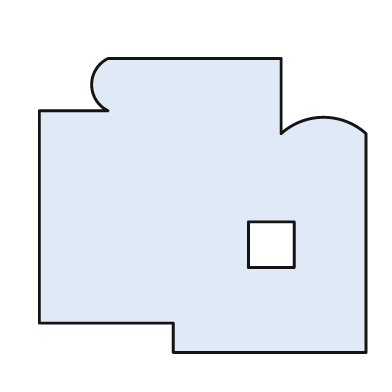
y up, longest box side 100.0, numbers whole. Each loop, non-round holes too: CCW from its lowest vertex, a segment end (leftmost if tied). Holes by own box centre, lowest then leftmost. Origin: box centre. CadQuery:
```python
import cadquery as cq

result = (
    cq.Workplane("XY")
    .moveTo(-9.0, -45.0)
    .lineTo(50.0, -45.0)
    .lineTo(50.0, 22.0)
    .threePointArc((37.0, 27.0), (24.0, 22.0))
    .lineTo(24.0, 45.0)
    .lineTo(-29.0, 45.0)
    .threePointArc((-34.0, 37.0), (-29.0, 29.0))
    .lineTo(-50.0, 29.0)
    .lineTo(-50.0, -36.0)
    .lineTo(-9.0, -36.0)
    .close()
    .moveTo(14.0, -19.0)
    .lineTo(28.0, -19.0)
    .lineTo(28.0, -5.0)
    .lineTo(14.0, -5.0)
    .close()
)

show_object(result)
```